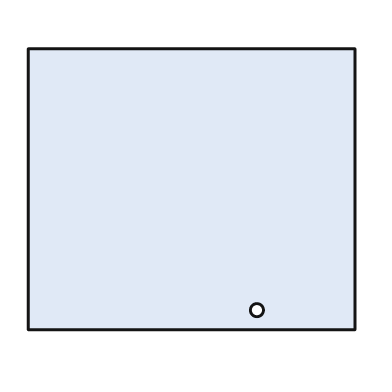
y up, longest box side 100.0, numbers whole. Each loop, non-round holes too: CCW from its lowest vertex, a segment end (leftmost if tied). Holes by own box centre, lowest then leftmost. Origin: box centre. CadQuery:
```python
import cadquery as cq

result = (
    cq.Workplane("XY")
    .moveTo(-50.0, -43.0)
    .lineTo(50.0, -43.0)
    .lineTo(50.0, 43.0)
    .lineTo(-50.0, 43.0)
    .close()
    .moveTo(20.0, -37.0)
    .circle(2.0)
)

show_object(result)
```